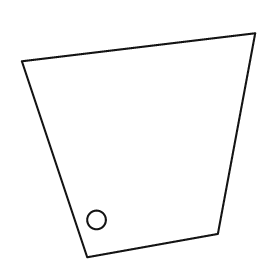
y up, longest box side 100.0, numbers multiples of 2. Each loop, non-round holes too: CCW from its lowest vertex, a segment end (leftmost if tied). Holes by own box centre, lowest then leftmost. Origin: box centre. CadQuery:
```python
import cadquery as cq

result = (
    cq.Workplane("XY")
    .moveTo(-22.0, -48.0)
    .lineTo(34.0, -38.0)
    .lineTo(50.0, 48.0)
    .lineTo(-50.0, 36.0)
    .close()
    .moveTo(-18.0, -32.0)
    .circle(4.0)
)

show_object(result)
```